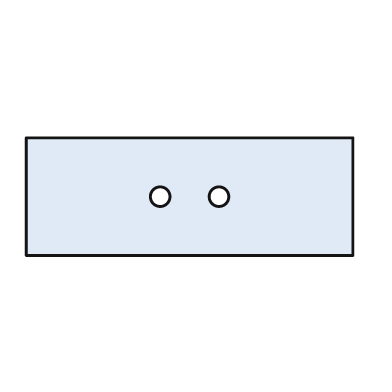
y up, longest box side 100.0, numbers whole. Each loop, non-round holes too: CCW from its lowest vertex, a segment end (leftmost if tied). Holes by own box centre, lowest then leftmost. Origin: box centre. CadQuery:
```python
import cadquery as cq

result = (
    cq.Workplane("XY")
    .moveTo(-50.0, -18.0)
    .lineTo(50.0, -18.0)
    .lineTo(50.0, 18.0)
    .lineTo(-50.0, 18.0)
    .close()
    .moveTo(-9.0, 0.0)
    .circle(3.0)
    .moveTo(9.0, 0.0)
    .circle(3.0)
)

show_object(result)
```